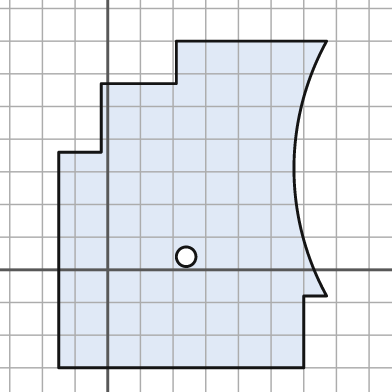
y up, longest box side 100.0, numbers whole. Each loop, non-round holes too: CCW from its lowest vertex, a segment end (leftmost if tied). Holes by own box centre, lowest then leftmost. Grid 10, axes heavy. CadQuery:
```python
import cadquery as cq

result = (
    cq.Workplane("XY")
    .moveTo(-15.0, -30.0)
    .lineTo(60.0, -30.0)
    .lineTo(60.0, -8.0)
    .lineTo(67.0, -8.0)
    .threePointArc((57.0, 31.0), (67.0, 70.0))
    .lineTo(21.0, 70.0)
    .lineTo(21.0, 57.0)
    .lineTo(-2.0, 57.0)
    .lineTo(-2.0, 36.0)
    .lineTo(-15.0, 36.0)
    .close()
    .moveTo(24.0, 4.0)
    .circle(3.0)
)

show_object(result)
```